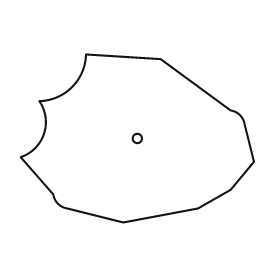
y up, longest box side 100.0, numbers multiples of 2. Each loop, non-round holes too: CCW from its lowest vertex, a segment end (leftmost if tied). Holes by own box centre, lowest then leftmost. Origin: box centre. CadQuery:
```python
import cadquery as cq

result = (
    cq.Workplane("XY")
    .moveTo(-6.0, -36.0)
    .lineTo(26.0, -30.0)
    .lineTo(40.0, -22.0)
    .lineTo(50.0, -10.0)
    .lineTo(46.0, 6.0)
    .threePointArc((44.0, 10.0), (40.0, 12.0))
    .lineTo(10.0, 34.0)
    .lineTo(-22.0, 36.0)
    .threePointArc((-28.0, 22.0), (-42.0, 16.0))
    .threePointArc((-40.0, 2.0), (-50.0, -8.0))
    .lineTo(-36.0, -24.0)
    .threePointArc((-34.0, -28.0), (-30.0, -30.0))
    .close()
    .moveTo(0.0, 0.0)
    .circle(2.0)
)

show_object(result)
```